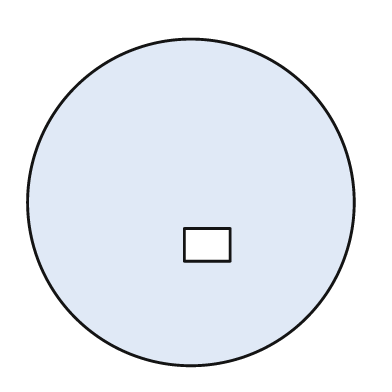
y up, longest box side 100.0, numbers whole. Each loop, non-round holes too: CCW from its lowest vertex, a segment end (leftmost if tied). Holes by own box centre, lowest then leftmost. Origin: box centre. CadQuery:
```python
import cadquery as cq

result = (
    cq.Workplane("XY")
    .moveTo(0.0, 0.0)
    .circle(50.0)
    .moveTo(-2.0, -18.0)
    .lineTo(12.0, -18.0)
    .lineTo(12.0, -8.0)
    .lineTo(-2.0, -8.0)
    .close()
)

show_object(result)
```